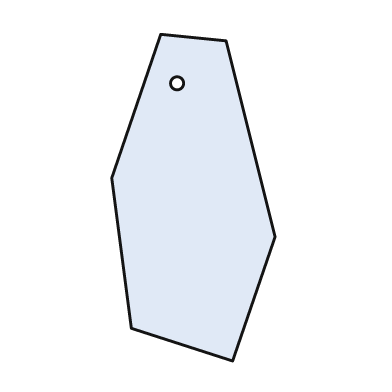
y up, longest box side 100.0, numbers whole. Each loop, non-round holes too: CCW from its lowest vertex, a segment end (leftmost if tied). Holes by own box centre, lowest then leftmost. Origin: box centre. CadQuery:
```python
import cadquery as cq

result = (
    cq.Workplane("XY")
    .moveTo(12.0, -50.0)
    .lineTo(25.0, -12.0)
    .lineTo(10.0, 48.0)
    .lineTo(-10.0, 50.0)
    .lineTo(-25.0, 6.0)
    .lineTo(-19.0, -40.0)
    .close()
    .moveTo(-5.0, 35.0)
    .circle(2.0)
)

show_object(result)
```